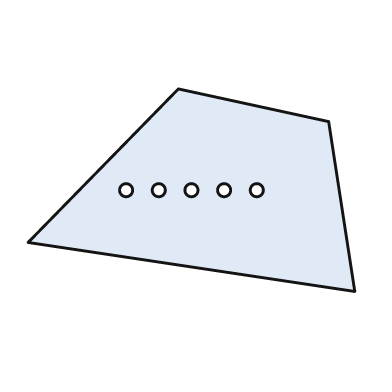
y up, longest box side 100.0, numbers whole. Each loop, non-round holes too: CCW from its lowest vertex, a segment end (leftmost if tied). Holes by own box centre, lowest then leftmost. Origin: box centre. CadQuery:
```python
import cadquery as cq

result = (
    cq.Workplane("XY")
    .moveTo(50.0, -31.0)
    .lineTo(42.0, 21.0)
    .lineTo(-4.0, 31.0)
    .lineTo(-50.0, -16.0)
    .close()
    .moveTo(-20.0, 0.0)
    .circle(2.0)
    .moveTo(-10.0, 0.0)
    .circle(2.0)
    .moveTo(0.0, 0.0)
    .circle(2.0)
    .moveTo(10.0, 0.0)
    .circle(2.0)
    .moveTo(20.0, 0.0)
    .circle(2.0)
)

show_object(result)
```